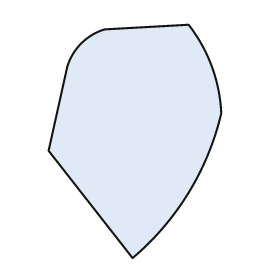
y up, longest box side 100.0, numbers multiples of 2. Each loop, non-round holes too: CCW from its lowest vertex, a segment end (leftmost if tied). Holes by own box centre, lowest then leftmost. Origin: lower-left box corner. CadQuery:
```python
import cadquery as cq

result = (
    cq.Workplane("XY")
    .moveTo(36.0, 0.0)
    .threePointArc((60.0, 28.0), (74.0, 62.0))
    .threePointArc((70.0, 82.0), (60.0, 100.0))
    .lineTo(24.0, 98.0)
    .threePointArc((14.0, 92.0), (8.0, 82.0))
    .lineTo(0.0, 46.0)
    .close()
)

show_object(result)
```